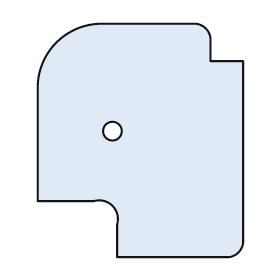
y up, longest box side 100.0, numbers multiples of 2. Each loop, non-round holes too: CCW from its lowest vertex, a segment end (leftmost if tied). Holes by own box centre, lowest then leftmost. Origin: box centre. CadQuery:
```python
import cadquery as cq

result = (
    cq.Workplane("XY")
    .moveTo(-10.0, -50.0)
    .lineTo(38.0, -50.0)
    .threePointArc((42.0, -48.0), (44.0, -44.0))
    .lineTo(44.0, 34.0)
    .lineTo(30.0, 34.0)
    .lineTo(30.0, 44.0)
    .threePointArc((28.0, 48.0), (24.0, 50.0))
    .lineTo(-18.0, 50.0)
    .threePointArc((-36.0, 42.0), (-44.0, 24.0))
    .lineTo(-44.0, -26.0)
    .lineTo(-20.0, -26.0)
    .threePointArc((-12.0, -28.0), (-10.0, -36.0))
    .close()
    .moveTo(-12.0, 4.0)
    .circle(4.0)
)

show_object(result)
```